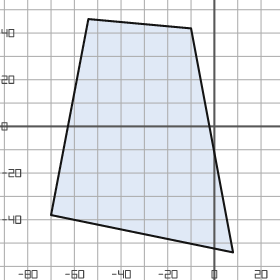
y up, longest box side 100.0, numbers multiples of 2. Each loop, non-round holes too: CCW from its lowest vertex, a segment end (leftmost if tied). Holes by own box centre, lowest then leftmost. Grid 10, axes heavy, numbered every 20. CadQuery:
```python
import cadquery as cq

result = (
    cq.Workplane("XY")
    .moveTo(8.0, -54.0)
    .lineTo(-10.0, 42.0)
    .lineTo(-54.0, 46.0)
    .lineTo(-70.0, -38.0)
    .close()
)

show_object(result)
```